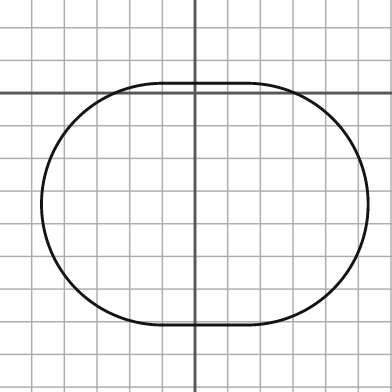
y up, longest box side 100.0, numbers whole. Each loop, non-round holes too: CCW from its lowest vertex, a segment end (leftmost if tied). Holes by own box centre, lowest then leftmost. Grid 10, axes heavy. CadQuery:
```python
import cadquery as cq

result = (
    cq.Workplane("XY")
    .moveTo(-10.0, -71.0)
    .lineTo(16.0, -71.0)
    .threePointArc((53.0, -34.0), (16.0, 3.0))
    .lineTo(-10.0, 3.0)
    .threePointArc((-47.0, -34.0), (-10.0, -71.0))
    .close()
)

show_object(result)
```